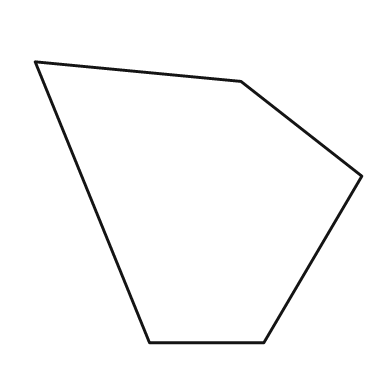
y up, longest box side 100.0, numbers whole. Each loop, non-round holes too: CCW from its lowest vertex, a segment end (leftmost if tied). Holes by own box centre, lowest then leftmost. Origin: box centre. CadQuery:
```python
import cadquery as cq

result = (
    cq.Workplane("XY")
    .moveTo(-15.0, -43.0)
    .lineTo(20.0, -43.0)
    .lineTo(50.0, 8.0)
    .lineTo(13.0, 37.0)
    .lineTo(-50.0, 43.0)
    .close()
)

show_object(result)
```